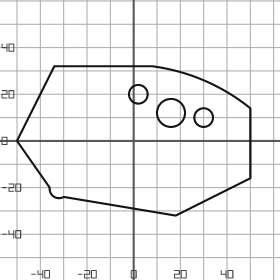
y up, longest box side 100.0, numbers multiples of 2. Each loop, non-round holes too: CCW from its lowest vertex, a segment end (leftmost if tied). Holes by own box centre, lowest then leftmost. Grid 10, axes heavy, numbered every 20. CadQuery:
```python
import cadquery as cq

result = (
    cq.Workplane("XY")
    .moveTo(18.0, -32.0)
    .lineTo(50.0, -16.0)
    .lineTo(50.0, 14.0)
    .threePointArc((30.0, 26.0), (8.0, 32.0))
    .lineTo(-34.0, 32.0)
    .lineTo(-50.0, 0.0)
    .lineTo(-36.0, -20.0)
    .threePointArc((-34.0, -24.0), (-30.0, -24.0))
    .close()
    .moveTo(30.0, 10.0)
    .circle(4.0)
    .moveTo(16.0, 12.0)
    .circle(6.0)
    .moveTo(2.0, 20.0)
    .circle(4.0)
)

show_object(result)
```